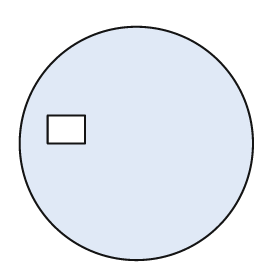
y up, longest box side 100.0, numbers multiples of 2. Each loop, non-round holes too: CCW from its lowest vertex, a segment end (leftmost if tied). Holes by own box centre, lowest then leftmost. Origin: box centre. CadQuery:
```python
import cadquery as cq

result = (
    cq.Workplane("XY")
    .moveTo(0.0, 0.0)
    .circle(50.0)
    .moveTo(-38.0, 0.0)
    .lineTo(-22.0, 0.0)
    .lineTo(-22.0, 12.0)
    .lineTo(-38.0, 12.0)
    .close()
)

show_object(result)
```